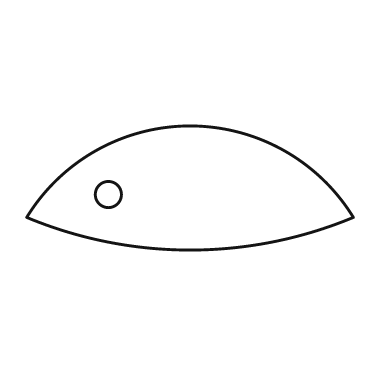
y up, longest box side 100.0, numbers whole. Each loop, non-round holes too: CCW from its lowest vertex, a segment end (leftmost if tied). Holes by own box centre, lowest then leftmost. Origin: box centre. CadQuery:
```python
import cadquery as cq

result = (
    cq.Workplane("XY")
    .moveTo(-50.0, -9.0)
    .threePointArc((0.0, -19.0), (50.0, -9.0))
    .threePointArc((0.0, 19.0), (-50.0, -9.0))
    .close()
    .moveTo(-25.0, -2.0)
    .circle(4.0)
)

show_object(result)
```